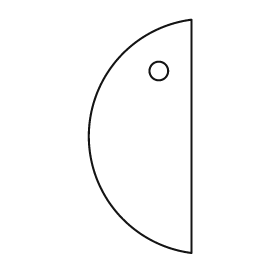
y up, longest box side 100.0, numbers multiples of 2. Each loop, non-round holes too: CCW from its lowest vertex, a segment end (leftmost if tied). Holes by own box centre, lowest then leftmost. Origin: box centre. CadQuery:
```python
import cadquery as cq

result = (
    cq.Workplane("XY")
    .moveTo(22.0, -50.0)
    .lineTo(22.0, 50.0)
    .threePointArc((-22.0, 0.0), (22.0, -50.0))
    .close()
    .moveTo(8.0, 28.0)
    .circle(4.0)
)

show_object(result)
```